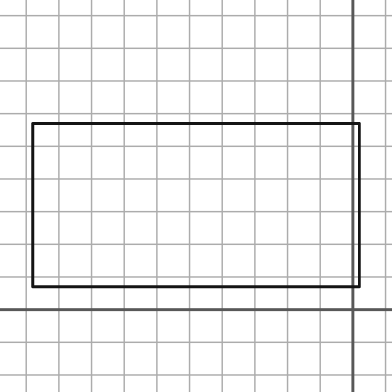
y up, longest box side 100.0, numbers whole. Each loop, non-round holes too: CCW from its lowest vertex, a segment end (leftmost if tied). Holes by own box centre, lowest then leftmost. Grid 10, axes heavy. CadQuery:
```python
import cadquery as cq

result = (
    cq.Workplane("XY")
    .moveTo(-98.0, 7.0)
    .lineTo(2.0, 7.0)
    .lineTo(2.0, 57.0)
    .lineTo(-98.0, 57.0)
    .close()
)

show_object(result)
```